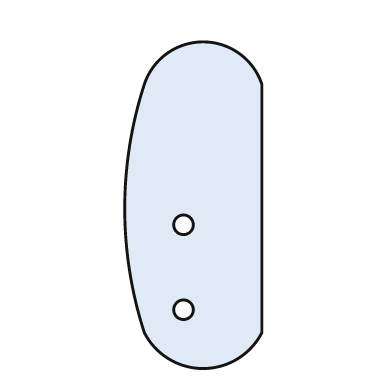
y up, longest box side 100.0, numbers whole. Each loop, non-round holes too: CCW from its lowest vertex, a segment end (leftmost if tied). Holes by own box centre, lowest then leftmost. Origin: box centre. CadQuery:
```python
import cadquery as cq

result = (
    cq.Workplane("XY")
    .moveTo(-15.0, -39.0)
    .threePointArc((3.0, -50.0), (21.0, -39.0))
    .lineTo(21.0, 37.0)
    .threePointArc((3.0, 50.0), (-15.0, 37.0))
    .threePointArc((-21.0, -1.0), (-15.0, -39.0))
    .close()
    .moveTo(-3.0, -32.0)
    .circle(3.0)
    .moveTo(-3.0, -6.0)
    .circle(3.0)
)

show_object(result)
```